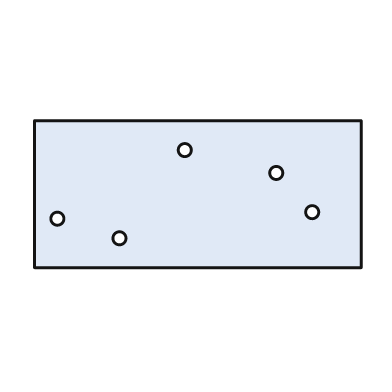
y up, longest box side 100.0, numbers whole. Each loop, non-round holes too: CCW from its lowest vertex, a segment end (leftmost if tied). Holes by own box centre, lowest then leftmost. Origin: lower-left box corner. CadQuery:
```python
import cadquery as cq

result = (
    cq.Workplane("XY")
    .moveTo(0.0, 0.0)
    .lineTo(100.0, 0.0)
    .lineTo(100.0, 45.0)
    .lineTo(0.0, 45.0)
    .close()
    .moveTo(26.0, 9.0)
    .circle(2.0)
    .moveTo(7.0, 15.0)
    .circle(2.0)
    .moveTo(85.0, 17.0)
    .circle(2.0)
    .moveTo(74.0, 29.0)
    .circle(2.0)
    .moveTo(46.0, 36.0)
    .circle(2.0)
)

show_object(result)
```